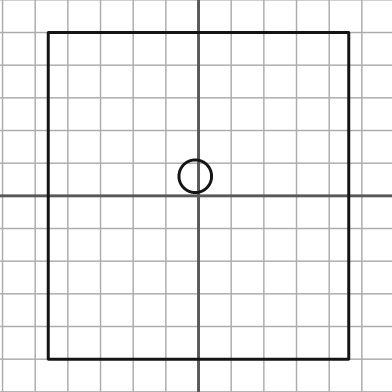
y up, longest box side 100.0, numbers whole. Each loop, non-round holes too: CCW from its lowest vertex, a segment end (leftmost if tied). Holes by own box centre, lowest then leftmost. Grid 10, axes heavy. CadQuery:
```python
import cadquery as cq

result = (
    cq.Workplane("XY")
    .moveTo(-46.0, -50.0)
    .lineTo(46.0, -50.0)
    .lineTo(46.0, 50.0)
    .lineTo(-46.0, 50.0)
    .close()
    .moveTo(-1.0, 6.0)
    .circle(5.0)
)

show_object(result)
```